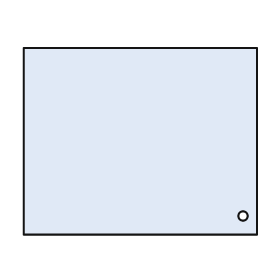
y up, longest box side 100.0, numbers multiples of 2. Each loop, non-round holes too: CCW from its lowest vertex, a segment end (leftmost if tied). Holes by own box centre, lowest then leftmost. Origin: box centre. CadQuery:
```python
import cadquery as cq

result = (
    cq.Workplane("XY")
    .moveTo(-50.0, -40.0)
    .lineTo(50.0, -40.0)
    .lineTo(50.0, 40.0)
    .lineTo(-50.0, 40.0)
    .close()
    .moveTo(44.0, -32.0)
    .circle(2.0)
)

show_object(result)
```